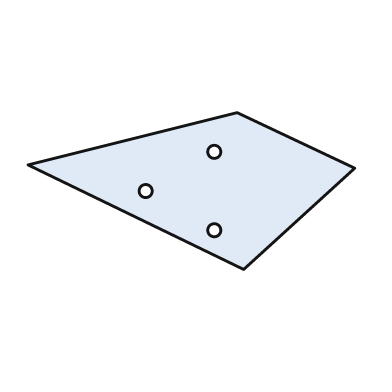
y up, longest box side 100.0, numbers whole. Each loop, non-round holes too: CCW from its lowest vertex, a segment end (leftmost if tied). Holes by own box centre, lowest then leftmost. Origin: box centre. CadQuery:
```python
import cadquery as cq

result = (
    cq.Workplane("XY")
    .moveTo(16.0, -24.0)
    .lineTo(50.0, 7.0)
    .lineTo(14.0, 24.0)
    .lineTo(-50.0, 8.0)
    .close()
    .moveTo(7.0, -12.0)
    .circle(2.0)
    .moveTo(-14.0, 0.0)
    .circle(2.0)
    .moveTo(7.0, 12.0)
    .circle(2.0)
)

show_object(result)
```